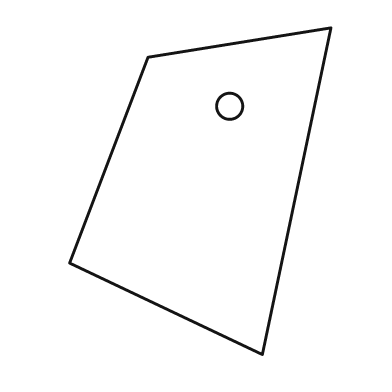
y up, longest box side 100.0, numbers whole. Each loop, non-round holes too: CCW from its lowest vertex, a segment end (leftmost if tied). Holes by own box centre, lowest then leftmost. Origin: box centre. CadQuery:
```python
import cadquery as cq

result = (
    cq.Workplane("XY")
    .moveTo(19.0, -50.0)
    .lineTo(40.0, 50.0)
    .lineTo(-16.0, 41.0)
    .lineTo(-40.0, -22.0)
    .close()
    .moveTo(9.0, 26.0)
    .circle(4.0)
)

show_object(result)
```